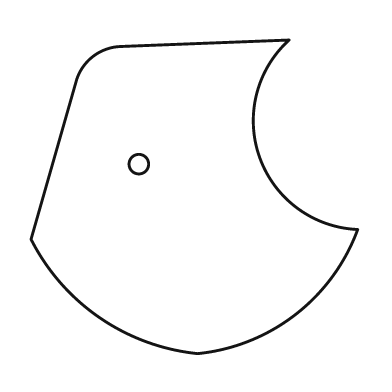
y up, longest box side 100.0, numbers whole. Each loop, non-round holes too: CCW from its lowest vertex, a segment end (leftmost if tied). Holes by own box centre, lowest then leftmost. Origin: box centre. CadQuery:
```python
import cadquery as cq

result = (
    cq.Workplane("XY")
    .moveTo(1.0, -48.0)
    .threePointArc((31.0, -36.0), (50.0, -10.0))
    .threePointArc((20.0, 12.0), (29.0, 48.0))
    .lineTo(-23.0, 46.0)
    .threePointArc((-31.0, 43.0), (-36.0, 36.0))
    .lineTo(-50.0, -13.0)
    .threePointArc((-29.0, -37.0), (1.0, -48.0))
    .close()
    .moveTo(-17.0, 10.0)
    .circle(3.0)
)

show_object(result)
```